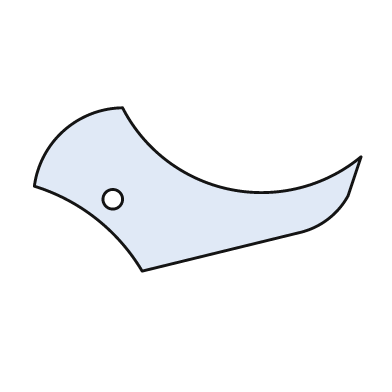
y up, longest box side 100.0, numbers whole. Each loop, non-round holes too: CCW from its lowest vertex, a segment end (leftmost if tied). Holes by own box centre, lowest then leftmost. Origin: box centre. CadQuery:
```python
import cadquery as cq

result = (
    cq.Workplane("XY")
    .moveTo(-17.0, -25.0)
    .lineTo(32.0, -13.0)
    .threePointArc((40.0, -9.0), (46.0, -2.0))
    .lineTo(50.0, 10.0)
    .threePointArc((10.0, 0.0), (-23.0, 25.0))
    .threePointArc((-41.0, 18.0), (-50.0, 1.0))
    .threePointArc((-31.0, -9.0), (-17.0, -25.0))
    .close()
    .moveTo(-26.0, -3.0)
    .circle(3.0)
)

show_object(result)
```